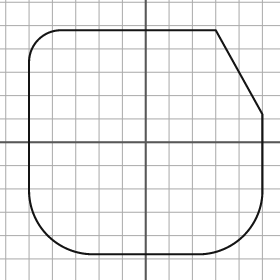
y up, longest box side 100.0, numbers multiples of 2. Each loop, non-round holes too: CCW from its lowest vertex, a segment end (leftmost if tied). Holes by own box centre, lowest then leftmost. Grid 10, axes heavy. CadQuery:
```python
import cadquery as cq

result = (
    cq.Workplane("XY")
    .moveTo(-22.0, -48.0)
    .lineTo(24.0, -48.0)
    .threePointArc((42.0, -40.0), (50.0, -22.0))
    .lineTo(50.0, 12.0)
    .lineTo(30.0, 48.0)
    .lineTo(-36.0, 48.0)
    .threePointArc((-46.0, 44.0), (-50.0, 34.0))
    .lineTo(-50.0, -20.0)
    .threePointArc((-42.0, -40.0), (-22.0, -48.0))
    .close()
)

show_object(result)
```